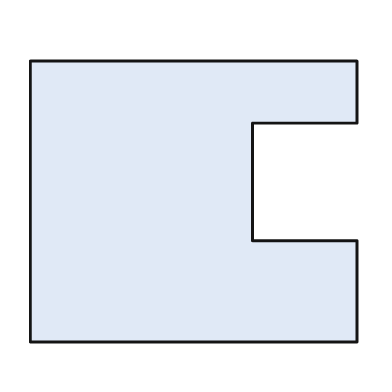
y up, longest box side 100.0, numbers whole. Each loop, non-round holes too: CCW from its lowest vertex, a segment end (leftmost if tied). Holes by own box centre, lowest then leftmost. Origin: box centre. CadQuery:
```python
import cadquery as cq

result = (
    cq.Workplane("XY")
    .moveTo(-50.0, -43.0)
    .lineTo(50.0, -43.0)
    .lineTo(50.0, -12.0)
    .lineTo(18.0, -12.0)
    .lineTo(18.0, 24.0)
    .lineTo(50.0, 24.0)
    .lineTo(50.0, 43.0)
    .lineTo(-50.0, 43.0)
    .close()
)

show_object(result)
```